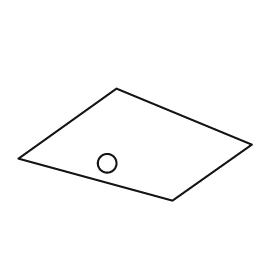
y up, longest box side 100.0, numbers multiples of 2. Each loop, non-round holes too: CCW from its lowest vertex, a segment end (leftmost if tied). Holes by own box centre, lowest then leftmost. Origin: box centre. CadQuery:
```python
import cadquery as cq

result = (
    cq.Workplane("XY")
    .moveTo(16.0, -24.0)
    .lineTo(50.0, 0.0)
    .lineTo(-8.0, 24.0)
    .lineTo(-50.0, -6.0)
    .close()
    .moveTo(-12.0, -8.0)
    .circle(4.0)
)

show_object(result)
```